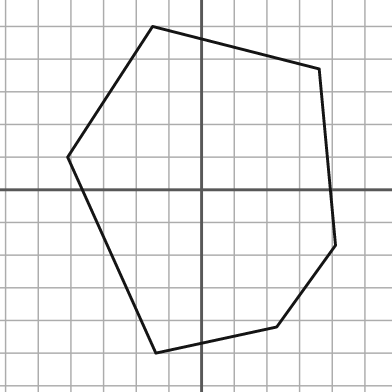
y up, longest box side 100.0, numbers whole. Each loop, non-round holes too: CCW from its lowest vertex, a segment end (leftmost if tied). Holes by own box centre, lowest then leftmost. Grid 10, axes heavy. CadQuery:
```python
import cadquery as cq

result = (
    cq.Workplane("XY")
    .moveTo(-14.0, -50.0)
    .lineTo(23.0, -42.0)
    .lineTo(41.0, -17.0)
    .lineTo(36.0, 37.0)
    .lineTo(-15.0, 50.0)
    .lineTo(-41.0, 10.0)
    .close()
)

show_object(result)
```